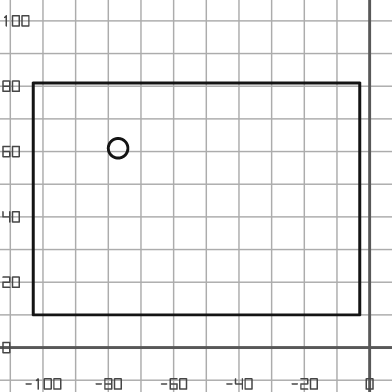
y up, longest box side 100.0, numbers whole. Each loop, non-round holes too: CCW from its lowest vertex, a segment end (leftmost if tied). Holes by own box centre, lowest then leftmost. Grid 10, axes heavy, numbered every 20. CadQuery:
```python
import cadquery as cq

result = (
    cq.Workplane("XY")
    .moveTo(-103.0, 10.0)
    .lineTo(-3.0, 10.0)
    .lineTo(-3.0, 81.0)
    .lineTo(-103.0, 81.0)
    .close()
    .moveTo(-77.0, 61.0)
    .circle(3.0)
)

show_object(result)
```